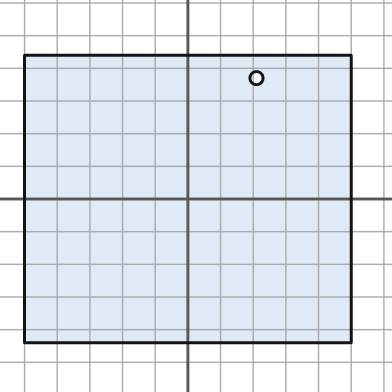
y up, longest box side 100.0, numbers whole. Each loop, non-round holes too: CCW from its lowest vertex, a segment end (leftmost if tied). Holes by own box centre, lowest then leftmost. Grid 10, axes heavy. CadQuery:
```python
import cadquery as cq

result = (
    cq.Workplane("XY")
    .moveTo(-50.0, -44.0)
    .lineTo(50.0, -44.0)
    .lineTo(50.0, 44.0)
    .lineTo(-50.0, 44.0)
    .close()
    .moveTo(21.0, 37.0)
    .circle(2.0)
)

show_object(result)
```